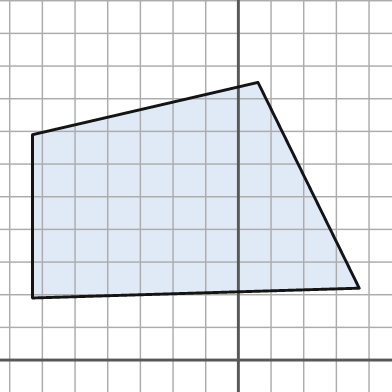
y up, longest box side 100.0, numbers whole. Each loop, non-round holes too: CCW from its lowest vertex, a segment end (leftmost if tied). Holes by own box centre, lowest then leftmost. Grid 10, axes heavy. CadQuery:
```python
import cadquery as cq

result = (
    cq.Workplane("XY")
    .moveTo(-63.0, 19.0)
    .lineTo(37.0, 22.0)
    .lineTo(6.0, 85.0)
    .lineTo(-63.0, 69.0)
    .close()
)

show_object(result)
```